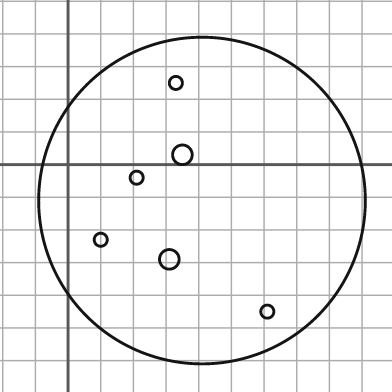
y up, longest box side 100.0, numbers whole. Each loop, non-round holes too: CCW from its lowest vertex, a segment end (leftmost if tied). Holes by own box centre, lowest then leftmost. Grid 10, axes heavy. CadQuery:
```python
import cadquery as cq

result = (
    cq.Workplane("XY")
    .moveTo(41.0, -11.0)
    .circle(50.0)
    .moveTo(61.0, -45.0)
    .circle(2.0)
    .moveTo(31.0, -29.0)
    .circle(3.0)
    .moveTo(10.0, -23.0)
    .circle(2.0)
    .moveTo(21.0, -4.0)
    .circle(2.0)
    .moveTo(35.0, 3.0)
    .circle(3.0)
    .moveTo(33.0, 25.0)
    .circle(2.0)
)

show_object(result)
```